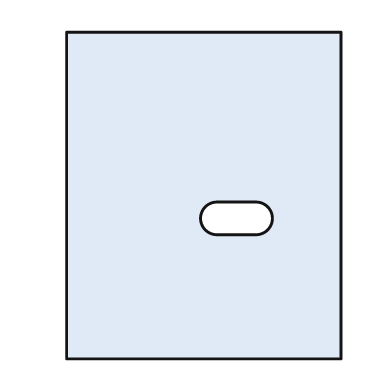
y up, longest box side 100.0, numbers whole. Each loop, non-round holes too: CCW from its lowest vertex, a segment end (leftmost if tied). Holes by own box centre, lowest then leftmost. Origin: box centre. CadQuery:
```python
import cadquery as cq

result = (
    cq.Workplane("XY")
    .moveTo(-42.0, -50.0)
    .lineTo(42.0, -50.0)
    .lineTo(42.0, 50.0)
    .lineTo(-42.0, 50.0)
    .close()
    .moveTo(4.0, -12.0)
    .lineTo(16.0, -12.0)
    .threePointArc((21.0, -7.0), (16.0, -2.0))
    .lineTo(4.0, -2.0)
    .threePointArc((-1.0, -7.0), (4.0, -12.0))
    .close()
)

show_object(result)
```